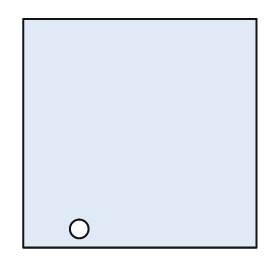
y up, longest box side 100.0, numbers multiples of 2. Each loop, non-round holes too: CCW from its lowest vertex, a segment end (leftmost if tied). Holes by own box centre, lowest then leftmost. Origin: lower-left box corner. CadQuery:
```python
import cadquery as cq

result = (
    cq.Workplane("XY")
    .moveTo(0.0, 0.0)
    .lineTo(100.0, 0.0)
    .lineTo(100.0, 98.0)
    .lineTo(0.0, 98.0)
    .close()
    .moveTo(24.0, 8.0)
    .circle(4.0)
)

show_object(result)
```